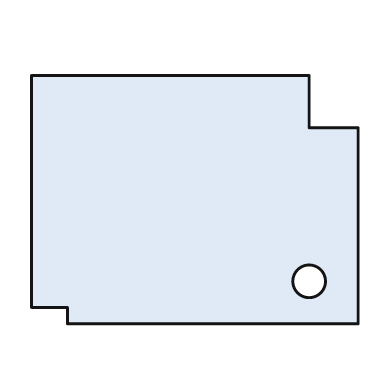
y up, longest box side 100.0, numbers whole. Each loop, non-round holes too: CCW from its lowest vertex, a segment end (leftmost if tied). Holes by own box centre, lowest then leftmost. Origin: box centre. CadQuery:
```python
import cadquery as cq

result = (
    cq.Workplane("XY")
    .moveTo(-39.0, -38.0)
    .lineTo(50.0, -38.0)
    .lineTo(50.0, 22.0)
    .lineTo(35.0, 22.0)
    .lineTo(35.0, 38.0)
    .lineTo(-50.0, 38.0)
    .lineTo(-50.0, -33.0)
    .lineTo(-39.0, -33.0)
    .close()
    .moveTo(35.0, -25.0)
    .circle(5.0)
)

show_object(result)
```